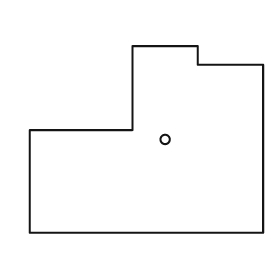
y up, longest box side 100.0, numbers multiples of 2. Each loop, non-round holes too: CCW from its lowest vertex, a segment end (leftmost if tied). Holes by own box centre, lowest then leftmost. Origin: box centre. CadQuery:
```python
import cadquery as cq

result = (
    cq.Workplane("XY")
    .moveTo(-50.0, -40.0)
    .lineTo(50.0, -40.0)
    .lineTo(50.0, 32.0)
    .lineTo(22.0, 32.0)
    .lineTo(22.0, 40.0)
    .lineTo(-6.0, 40.0)
    .lineTo(-6.0, 4.0)
    .lineTo(-50.0, 4.0)
    .close()
    .moveTo(8.0, 0.0)
    .circle(2.0)
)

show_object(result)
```